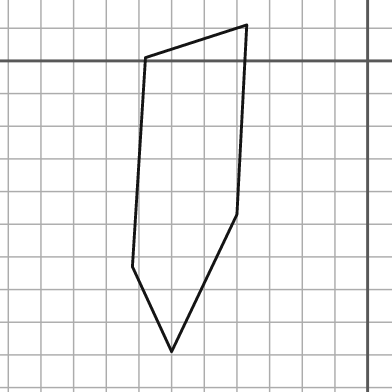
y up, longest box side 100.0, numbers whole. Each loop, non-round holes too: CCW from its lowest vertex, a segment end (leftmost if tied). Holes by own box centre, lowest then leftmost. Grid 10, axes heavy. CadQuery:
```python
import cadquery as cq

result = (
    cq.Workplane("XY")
    .moveTo(-60.0, -89.0)
    .lineTo(-40.0, -47.0)
    .lineTo(-37.0, 11.0)
    .lineTo(-68.0, 1.0)
    .lineTo(-72.0, -63.0)
    .close()
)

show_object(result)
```